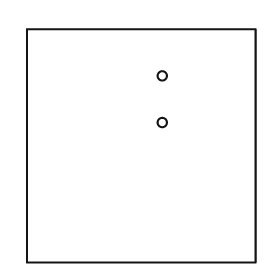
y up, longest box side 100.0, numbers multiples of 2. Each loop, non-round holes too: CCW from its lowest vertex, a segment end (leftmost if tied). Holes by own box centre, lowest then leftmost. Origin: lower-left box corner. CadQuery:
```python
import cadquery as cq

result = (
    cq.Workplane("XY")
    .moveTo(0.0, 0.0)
    .lineTo(98.0, 0.0)
    .lineTo(98.0, 100.0)
    .lineTo(0.0, 100.0)
    .close()
    .moveTo(58.0, 60.0)
    .circle(2.0)
    .moveTo(58.0, 80.0)
    .circle(2.0)
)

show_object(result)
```